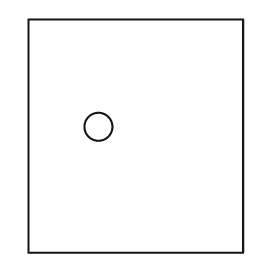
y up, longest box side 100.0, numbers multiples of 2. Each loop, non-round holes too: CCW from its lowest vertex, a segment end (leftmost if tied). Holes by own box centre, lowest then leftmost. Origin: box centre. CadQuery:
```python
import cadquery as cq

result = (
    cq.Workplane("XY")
    .moveTo(-46.0, -50.0)
    .lineTo(46.0, -50.0)
    .lineTo(46.0, 50.0)
    .lineTo(-46.0, 50.0)
    .close()
    .moveTo(-16.0, 4.0)
    .circle(6.0)
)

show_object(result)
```